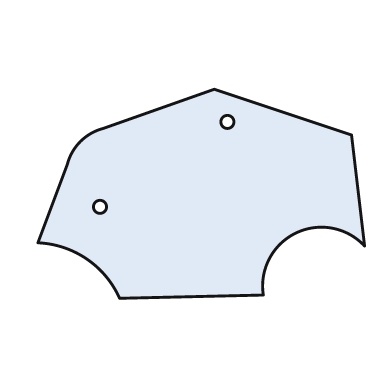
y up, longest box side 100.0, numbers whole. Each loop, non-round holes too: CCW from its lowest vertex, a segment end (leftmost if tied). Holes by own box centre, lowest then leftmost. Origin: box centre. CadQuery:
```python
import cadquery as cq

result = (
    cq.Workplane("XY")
    .moveTo(-25.0, -32.0)
    .lineTo(19.0, -31.0)
    .threePointArc((29.0, -12.0), (50.0, -16.0))
    .lineTo(46.0, 18.0)
    .lineTo(4.0, 32.0)
    .lineTo(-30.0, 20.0)
    .threePointArc((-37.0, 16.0), (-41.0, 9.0))
    .lineTo(-50.0, -15.0)
    .threePointArc((-35.0, -20.0), (-25.0, -32.0))
    .close()
    .moveTo(-31.0, -4.0)
    .circle(2.0)
    .moveTo(8.0, 22.0)
    .circle(2.0)
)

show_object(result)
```